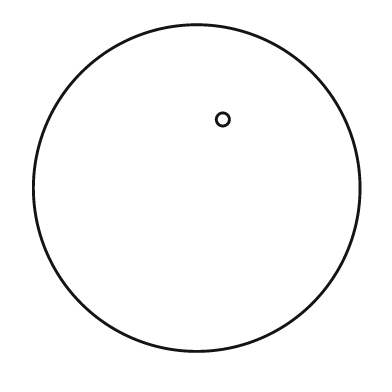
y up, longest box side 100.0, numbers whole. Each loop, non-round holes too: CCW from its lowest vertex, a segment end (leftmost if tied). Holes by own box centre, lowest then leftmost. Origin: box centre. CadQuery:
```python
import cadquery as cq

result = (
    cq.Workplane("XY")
    .moveTo(0.0, 0.0)
    .circle(50.0)
    .moveTo(8.0, 21.0)
    .circle(2.0)
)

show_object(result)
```